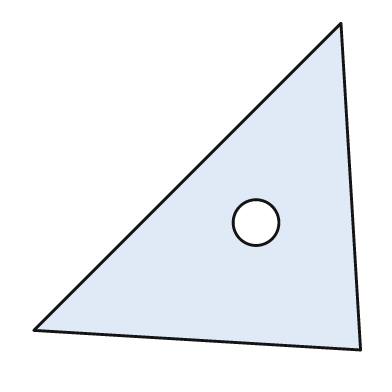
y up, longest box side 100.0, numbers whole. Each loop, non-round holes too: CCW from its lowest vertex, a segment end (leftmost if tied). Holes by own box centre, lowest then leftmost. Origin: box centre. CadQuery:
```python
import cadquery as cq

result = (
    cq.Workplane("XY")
    .moveTo(50.0, -50.0)
    .lineTo(44.0, 50.0)
    .lineTo(-50.0, -44.0)
    .close()
    .moveTo(18.0, -11.0)
    .circle(7.0)
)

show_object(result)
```